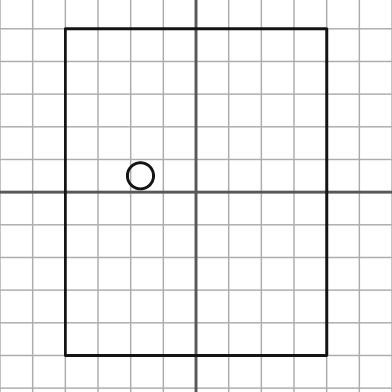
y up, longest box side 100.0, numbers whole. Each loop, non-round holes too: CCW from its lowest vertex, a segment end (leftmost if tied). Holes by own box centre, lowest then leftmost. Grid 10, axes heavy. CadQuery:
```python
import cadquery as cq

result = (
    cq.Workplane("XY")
    .moveTo(-40.0, -50.0)
    .lineTo(40.0, -50.0)
    .lineTo(40.0, 50.0)
    .lineTo(-40.0, 50.0)
    .close()
    .moveTo(-17.0, 5.0)
    .circle(4.0)
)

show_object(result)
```